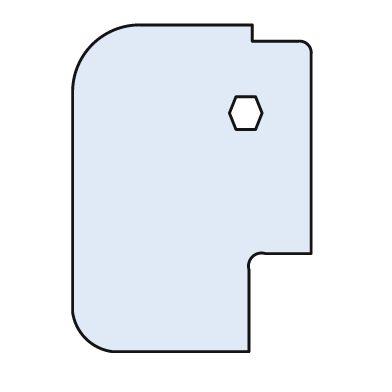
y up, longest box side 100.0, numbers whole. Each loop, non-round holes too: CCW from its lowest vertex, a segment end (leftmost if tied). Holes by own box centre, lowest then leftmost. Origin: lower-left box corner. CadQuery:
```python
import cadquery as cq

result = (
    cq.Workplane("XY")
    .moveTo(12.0, 0.0)
    .lineTo(54.0, 0.0)
    .lineTo(54.0, 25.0)
    .threePointArc((55.0, 29.0), (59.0, 30.0))
    .lineTo(73.0, 30.0)
    .lineTo(73.0, 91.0)
    .threePointArc((72.0, 94.0), (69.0, 95.0))
    .lineTo(55.0, 95.0)
    .lineTo(55.0, 100.0)
    .lineTo(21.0, 100.0)
    .threePointArc((6.0, 94.0), (0.0, 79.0))
    .lineTo(0.0, 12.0)
    .threePointArc((4.0, 4.0), (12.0, 0.0))
    .close()
    .moveTo(50.0, 68.0)
    .lineTo(56.0, 68.0)
    .lineTo(58.0, 73.0)
    .lineTo(56.0, 78.0)
    .lineTo(50.0, 78.0)
    .lineTo(48.0, 73.0)
    .close()
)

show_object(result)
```